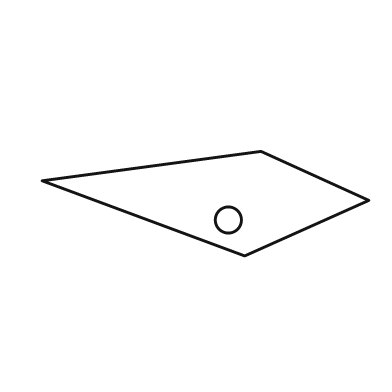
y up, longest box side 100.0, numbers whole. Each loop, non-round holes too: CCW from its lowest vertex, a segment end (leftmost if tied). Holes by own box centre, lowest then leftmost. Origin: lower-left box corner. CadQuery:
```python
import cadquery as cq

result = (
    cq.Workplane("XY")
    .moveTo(62.0, 0.0)
    .lineTo(100.0, 17.0)
    .lineTo(67.0, 32.0)
    .lineTo(0.0, 23.0)
    .close()
    .moveTo(57.0, 11.0)
    .circle(4.0)
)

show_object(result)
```